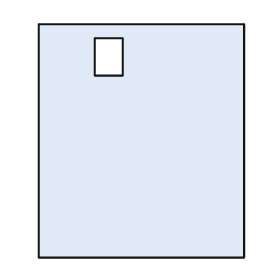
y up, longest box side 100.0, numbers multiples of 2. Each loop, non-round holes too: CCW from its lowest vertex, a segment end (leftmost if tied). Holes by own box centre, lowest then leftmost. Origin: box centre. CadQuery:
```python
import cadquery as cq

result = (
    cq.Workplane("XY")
    .moveTo(-44.0, -50.0)
    .lineTo(44.0, -50.0)
    .lineTo(44.0, 50.0)
    .lineTo(-44.0, 50.0)
    .close()
    .moveTo(-20.0, 28.0)
    .lineTo(-8.0, 28.0)
    .lineTo(-8.0, 44.0)
    .lineTo(-20.0, 44.0)
    .close()
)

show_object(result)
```